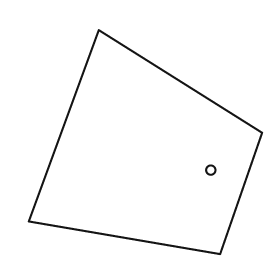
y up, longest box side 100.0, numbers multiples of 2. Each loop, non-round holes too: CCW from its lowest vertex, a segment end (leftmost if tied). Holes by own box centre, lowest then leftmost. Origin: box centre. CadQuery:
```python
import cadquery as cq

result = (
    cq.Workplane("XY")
    .moveTo(32.0, -48.0)
    .lineTo(50.0, 4.0)
    .lineTo(-20.0, 48.0)
    .lineTo(-50.0, -34.0)
    .close()
    .moveTo(28.0, -12.0)
    .circle(2.0)
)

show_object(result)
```